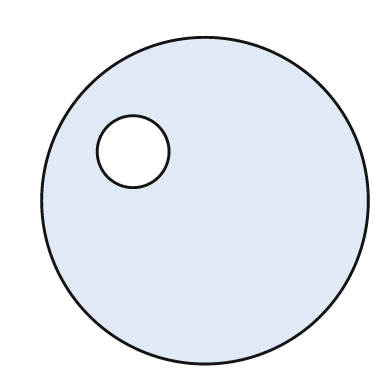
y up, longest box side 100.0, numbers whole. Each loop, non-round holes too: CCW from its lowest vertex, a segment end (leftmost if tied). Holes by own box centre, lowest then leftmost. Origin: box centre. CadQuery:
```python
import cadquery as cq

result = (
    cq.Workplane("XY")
    .moveTo(0.0, 0.0)
    .circle(50.0)
    .moveTo(-22.0, 15.0)
    .circle(11.0)
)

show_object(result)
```